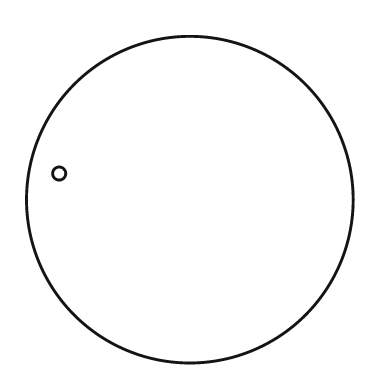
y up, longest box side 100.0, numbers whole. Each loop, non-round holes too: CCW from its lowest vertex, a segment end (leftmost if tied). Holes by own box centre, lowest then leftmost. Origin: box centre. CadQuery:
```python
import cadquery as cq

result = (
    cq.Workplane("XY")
    .moveTo(0.0, 0.0)
    .circle(50.0)
    .moveTo(-40.0, 8.0)
    .circle(2.0)
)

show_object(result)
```